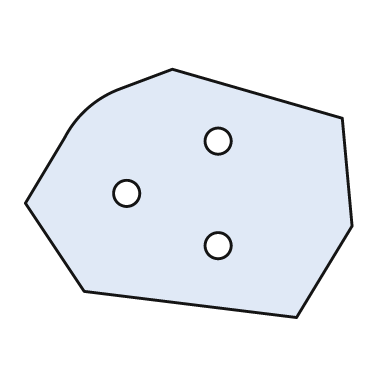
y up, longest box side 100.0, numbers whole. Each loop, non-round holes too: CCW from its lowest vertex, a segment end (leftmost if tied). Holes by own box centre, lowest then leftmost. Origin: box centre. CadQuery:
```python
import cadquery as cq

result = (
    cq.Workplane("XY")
    .moveTo(33.0, -38.0)
    .lineTo(50.0, -10.0)
    .lineTo(47.0, 23.0)
    .lineTo(-5.0, 38.0)
    .lineTo(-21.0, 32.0)
    .threePointArc((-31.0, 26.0), (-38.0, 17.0))
    .lineTo(-50.0, -3.0)
    .lineTo(-32.0, -30.0)
    .close()
    .moveTo(9.0, -16.0)
    .circle(4.0)
    .moveTo(-19.0, 0.0)
    .circle(4.0)
    .moveTo(9.0, 16.0)
    .circle(4.0)
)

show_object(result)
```